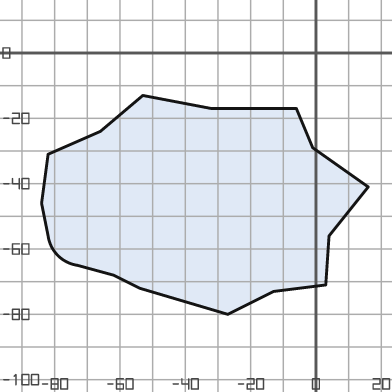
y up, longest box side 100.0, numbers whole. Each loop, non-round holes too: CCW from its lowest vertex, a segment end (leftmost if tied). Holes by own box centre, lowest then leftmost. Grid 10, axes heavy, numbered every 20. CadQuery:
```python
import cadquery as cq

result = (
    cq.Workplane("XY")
    .moveTo(-27.0, -80.0)
    .lineTo(-13.0, -73.0)
    .lineTo(3.0, -71.0)
    .lineTo(4.0, -56.0)
    .lineTo(16.0, -41.0)
    .lineTo(-1.0, -29.0)
    .lineTo(-6.0, -17.0)
    .lineTo(-32.0, -17.0)
    .lineTo(-53.0, -13.0)
    .lineTo(-66.0, -24.0)
    .lineTo(-82.0, -31.0)
    .lineTo(-84.0, -46.0)
    .lineTo(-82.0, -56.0)
    .threePointArc((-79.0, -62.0), (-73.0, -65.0))
    .lineTo(-62.0, -68.0)
    .lineTo(-54.0, -72.0)
    .close()
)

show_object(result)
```